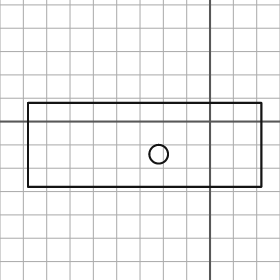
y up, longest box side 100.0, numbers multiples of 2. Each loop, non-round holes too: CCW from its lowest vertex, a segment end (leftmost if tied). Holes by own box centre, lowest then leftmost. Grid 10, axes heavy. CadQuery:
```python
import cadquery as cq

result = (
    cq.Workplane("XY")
    .moveTo(-78.0, -28.0)
    .lineTo(22.0, -28.0)
    .lineTo(22.0, 8.0)
    .lineTo(-78.0, 8.0)
    .close()
    .moveTo(-22.0, -14.0)
    .circle(4.0)
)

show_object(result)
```